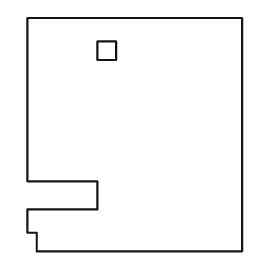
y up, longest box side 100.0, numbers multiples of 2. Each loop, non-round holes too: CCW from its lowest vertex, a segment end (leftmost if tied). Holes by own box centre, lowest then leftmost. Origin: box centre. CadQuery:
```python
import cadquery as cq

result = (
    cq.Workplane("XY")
    .moveTo(-42.0, -50.0)
    .lineTo(46.0, -50.0)
    .lineTo(46.0, 50.0)
    .lineTo(-46.0, 50.0)
    .lineTo(-46.0, -20.0)
    .lineTo(-16.0, -20.0)
    .lineTo(-16.0, -32.0)
    .lineTo(-46.0, -32.0)
    .lineTo(-46.0, -42.0)
    .lineTo(-42.0, -42.0)
    .close()
    .moveTo(-16.0, 32.0)
    .lineTo(-8.0, 32.0)
    .lineTo(-8.0, 40.0)
    .lineTo(-16.0, 40.0)
    .close()
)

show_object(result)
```